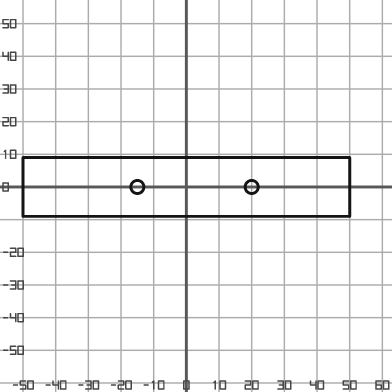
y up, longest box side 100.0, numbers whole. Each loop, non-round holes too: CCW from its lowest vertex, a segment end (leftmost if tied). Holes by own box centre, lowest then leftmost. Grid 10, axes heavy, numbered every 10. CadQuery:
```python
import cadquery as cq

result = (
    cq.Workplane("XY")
    .moveTo(-50.0, -9.0)
    .lineTo(50.0, -9.0)
    .lineTo(50.0, 9.0)
    .lineTo(-50.0, 9.0)
    .close()
    .moveTo(-15.0, 0.0)
    .circle(2.0)
    .moveTo(20.0, 0.0)
    .circle(2.0)
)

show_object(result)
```